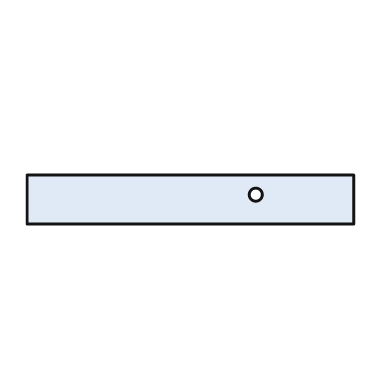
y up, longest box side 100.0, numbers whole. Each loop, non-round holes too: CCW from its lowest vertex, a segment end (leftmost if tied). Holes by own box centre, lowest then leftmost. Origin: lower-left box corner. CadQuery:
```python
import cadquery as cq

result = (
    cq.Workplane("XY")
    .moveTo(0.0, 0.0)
    .lineTo(100.0, 0.0)
    .lineTo(100.0, 15.0)
    .lineTo(0.0, 15.0)
    .close()
    .moveTo(70.0, 9.0)
    .circle(2.0)
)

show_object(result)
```